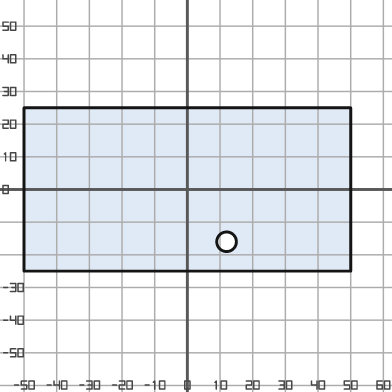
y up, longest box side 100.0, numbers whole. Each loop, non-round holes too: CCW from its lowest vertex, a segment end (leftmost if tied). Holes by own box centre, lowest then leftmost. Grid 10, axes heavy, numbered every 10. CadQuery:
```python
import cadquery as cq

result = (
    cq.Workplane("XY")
    .moveTo(-50.0, -25.0)
    .lineTo(50.0, -25.0)
    .lineTo(50.0, 25.0)
    .lineTo(-50.0, 25.0)
    .close()
    .moveTo(12.0, -16.0)
    .circle(3.0)
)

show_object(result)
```